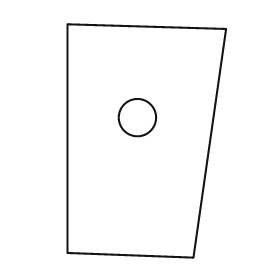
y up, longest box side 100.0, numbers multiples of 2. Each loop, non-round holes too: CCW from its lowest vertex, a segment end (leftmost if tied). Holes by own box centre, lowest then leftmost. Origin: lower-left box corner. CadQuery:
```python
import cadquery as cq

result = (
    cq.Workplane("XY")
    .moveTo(54.0, 0.0)
    .lineTo(68.0, 98.0)
    .lineTo(0.0, 100.0)
    .lineTo(0.0, 2.0)
    .close()
    .moveTo(30.0, 60.0)
    .circle(8.0)
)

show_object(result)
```